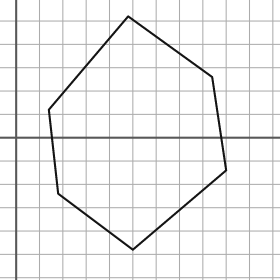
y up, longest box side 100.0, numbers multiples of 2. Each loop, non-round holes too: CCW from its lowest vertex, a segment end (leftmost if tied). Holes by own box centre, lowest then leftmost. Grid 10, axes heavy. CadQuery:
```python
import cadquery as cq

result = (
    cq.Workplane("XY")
    .moveTo(50.0, -48.0)
    .lineTo(90.0, -14.0)
    .lineTo(84.0, 26.0)
    .lineTo(48.0, 52.0)
    .lineTo(14.0, 12.0)
    .lineTo(18.0, -24.0)
    .close()
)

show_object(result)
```